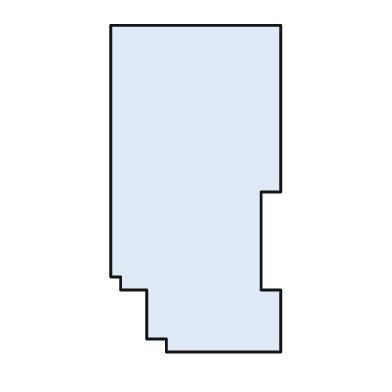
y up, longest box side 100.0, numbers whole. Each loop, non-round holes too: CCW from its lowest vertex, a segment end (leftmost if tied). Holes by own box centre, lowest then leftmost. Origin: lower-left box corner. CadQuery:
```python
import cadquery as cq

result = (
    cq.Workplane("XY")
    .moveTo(17.0, 0.0)
    .lineTo(52.0, 0.0)
    .lineTo(52.0, 19.0)
    .lineTo(46.0, 19.0)
    .lineTo(46.0, 49.0)
    .lineTo(52.0, 49.0)
    .lineTo(52.0, 100.0)
    .lineTo(0.0, 100.0)
    .lineTo(0.0, 23.0)
    .lineTo(3.0, 23.0)
    .lineTo(3.0, 19.0)
    .lineTo(11.0, 19.0)
    .lineTo(11.0, 4.0)
    .lineTo(17.0, 4.0)
    .close()
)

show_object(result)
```